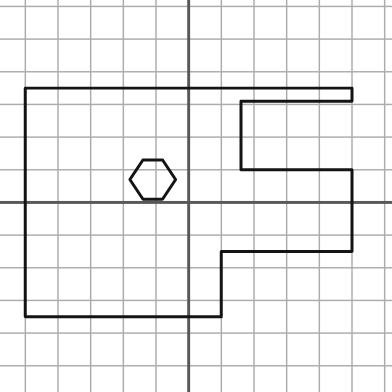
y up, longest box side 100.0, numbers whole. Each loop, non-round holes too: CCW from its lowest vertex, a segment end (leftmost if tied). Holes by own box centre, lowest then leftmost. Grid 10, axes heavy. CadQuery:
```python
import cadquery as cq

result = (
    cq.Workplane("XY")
    .moveTo(-50.0, -35.0)
    .lineTo(10.0, -35.0)
    .lineTo(10.0, -15.0)
    .lineTo(50.0, -15.0)
    .lineTo(50.0, 10.0)
    .lineTo(16.0, 10.0)
    .lineTo(16.0, 31.0)
    .lineTo(50.0, 31.0)
    .lineTo(50.0, 35.0)
    .lineTo(-50.0, 35.0)
    .close()
    .moveTo(-14.0, 1.0)
    .lineTo(-8.0, 1.0)
    .lineTo(-4.0, 7.0)
    .lineTo(-8.0, 13.0)
    .lineTo(-14.0, 13.0)
    .lineTo(-18.0, 7.0)
    .close()
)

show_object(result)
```